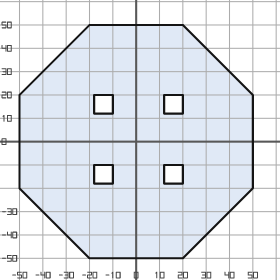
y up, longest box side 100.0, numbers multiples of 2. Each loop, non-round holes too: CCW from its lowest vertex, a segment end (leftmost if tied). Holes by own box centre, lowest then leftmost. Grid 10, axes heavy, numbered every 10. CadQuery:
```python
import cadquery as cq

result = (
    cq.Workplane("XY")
    .moveTo(-20.0, -50.0)
    .lineTo(20.0, -50.0)
    .lineTo(50.0, -20.0)
    .lineTo(50.0, 20.0)
    .lineTo(20.0, 50.0)
    .lineTo(-20.0, 50.0)
    .lineTo(-50.0, 20.0)
    .lineTo(-50.0, -20.0)
    .close()
    .moveTo(-18.0, -18.0)
    .lineTo(-10.0, -18.0)
    .lineTo(-10.0, -10.0)
    .lineTo(-18.0, -10.0)
    .close()
    .moveTo(12.0, -18.0)
    .lineTo(20.0, -18.0)
    .lineTo(20.0, -10.0)
    .lineTo(12.0, -10.0)
    .close()
    .moveTo(-18.0, 12.0)
    .lineTo(-10.0, 12.0)
    .lineTo(-10.0, 20.0)
    .lineTo(-18.0, 20.0)
    .close()
    .moveTo(12.0, 12.0)
    .lineTo(20.0, 12.0)
    .lineTo(20.0, 20.0)
    .lineTo(12.0, 20.0)
    .close()
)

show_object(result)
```